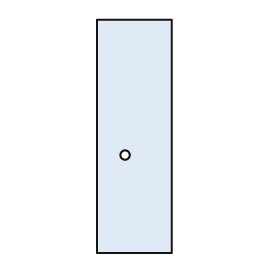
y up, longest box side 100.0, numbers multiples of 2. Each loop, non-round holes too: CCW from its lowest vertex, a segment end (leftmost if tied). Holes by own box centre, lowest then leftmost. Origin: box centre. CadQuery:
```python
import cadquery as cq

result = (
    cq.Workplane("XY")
    .moveTo(-16.0, -50.0)
    .lineTo(16.0, -50.0)
    .lineTo(16.0, 50.0)
    .lineTo(-16.0, 50.0)
    .close()
    .moveTo(-4.0, -8.0)
    .circle(2.0)
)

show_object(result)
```